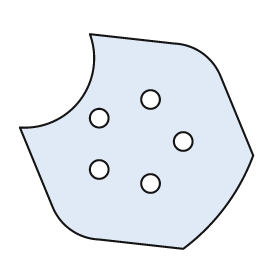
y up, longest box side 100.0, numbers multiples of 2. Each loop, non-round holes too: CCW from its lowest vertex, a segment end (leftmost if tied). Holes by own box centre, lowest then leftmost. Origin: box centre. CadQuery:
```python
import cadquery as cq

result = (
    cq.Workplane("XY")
    .moveTo(20.0, -46.0)
    .threePointArc((38.0, -28.0), (50.0, -6.0))
    .lineTo(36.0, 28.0)
    .threePointArc((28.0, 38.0), (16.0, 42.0))
    .lineTo(-20.0, 46.0)
    .threePointArc((-24.0, 18.0), (-50.0, 6.0))
    .lineTo(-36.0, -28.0)
    .threePointArc((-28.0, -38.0), (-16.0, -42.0))
    .close()
    .moveTo(6.0, -18.0)
    .circle(4.0)
    .moveTo(-16.0, -12.0)
    .circle(4.0)
    .moveTo(20.0, 0.0)
    .circle(4.0)
    .moveTo(-16.0, 10.0)
    .circle(4.0)
    .moveTo(6.0, 18.0)
    .circle(4.0)
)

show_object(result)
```